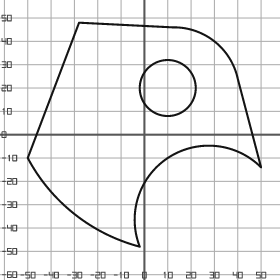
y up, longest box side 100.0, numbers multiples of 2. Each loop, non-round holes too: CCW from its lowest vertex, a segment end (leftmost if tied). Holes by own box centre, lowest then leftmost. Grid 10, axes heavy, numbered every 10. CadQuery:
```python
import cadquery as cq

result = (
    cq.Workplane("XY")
    .moveTo(-2.0, -48.0)
    .threePointArc((10.0, -10.0), (50.0, -14.0))
    .lineTo(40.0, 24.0)
    .threePointArc((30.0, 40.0), (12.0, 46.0))
    .lineTo(-28.0, 48.0)
    .lineTo(-50.0, -10.0)
    .threePointArc((-30.0, -34.0), (-2.0, -48.0))
    .close()
    .moveTo(10.0, 20.0)
    .circle(12.0)
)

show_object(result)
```